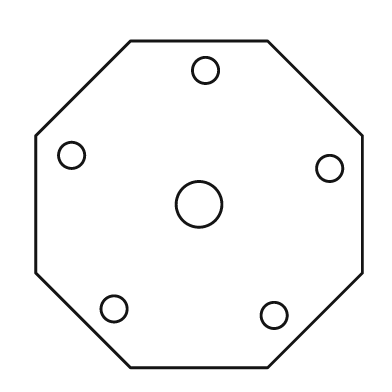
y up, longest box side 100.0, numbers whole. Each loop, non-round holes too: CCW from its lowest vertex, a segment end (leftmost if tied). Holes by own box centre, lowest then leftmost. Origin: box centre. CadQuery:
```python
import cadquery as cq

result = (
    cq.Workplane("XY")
    .moveTo(-21.0, -50.0)
    .lineTo(21.0, -50.0)
    .lineTo(50.0, -21.0)
    .lineTo(50.0, 21.0)
    .lineTo(21.0, 50.0)
    .lineTo(-21.0, 50.0)
    .lineTo(-50.0, 21.0)
    .lineTo(-50.0, -21.0)
    .close()
    .moveTo(23.0, -34.0)
    .circle(4.0)
    .moveTo(-26.0, -32.0)
    .circle(4.0)
    .moveTo(0.0, 0.0)
    .circle(7.0)
    .moveTo(40.0, 11.0)
    .circle(4.0)
    .moveTo(-39.0, 15.0)
    .circle(4.0)
    .moveTo(2.0, 41.0)
    .circle(4.0)
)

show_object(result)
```